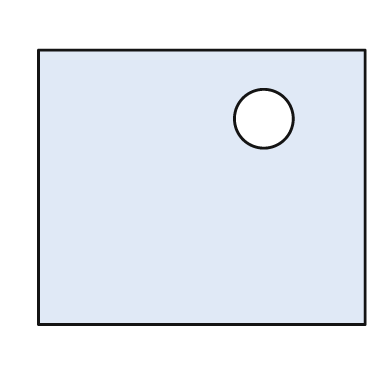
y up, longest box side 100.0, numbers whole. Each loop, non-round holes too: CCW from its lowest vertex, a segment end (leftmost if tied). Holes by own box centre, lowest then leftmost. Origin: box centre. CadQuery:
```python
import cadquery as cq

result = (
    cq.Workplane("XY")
    .moveTo(-50.0, -42.0)
    .lineTo(50.0, -42.0)
    .lineTo(50.0, 42.0)
    .lineTo(-50.0, 42.0)
    .close()
    .moveTo(19.0, 21.0)
    .circle(9.0)
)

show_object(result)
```